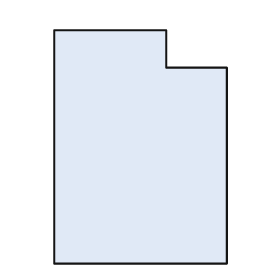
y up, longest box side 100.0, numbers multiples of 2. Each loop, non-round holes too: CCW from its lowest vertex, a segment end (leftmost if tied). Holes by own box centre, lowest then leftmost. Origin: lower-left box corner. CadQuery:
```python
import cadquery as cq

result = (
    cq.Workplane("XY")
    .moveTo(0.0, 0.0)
    .lineTo(74.0, 0.0)
    .lineTo(74.0, 84.0)
    .lineTo(48.0, 84.0)
    .lineTo(48.0, 100.0)
    .lineTo(0.0, 100.0)
    .close()
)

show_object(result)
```